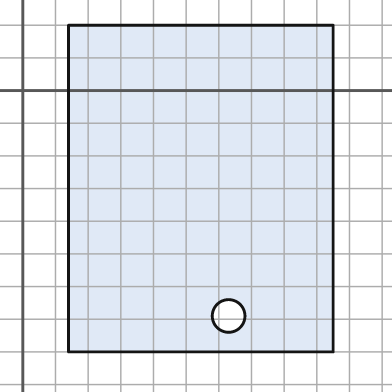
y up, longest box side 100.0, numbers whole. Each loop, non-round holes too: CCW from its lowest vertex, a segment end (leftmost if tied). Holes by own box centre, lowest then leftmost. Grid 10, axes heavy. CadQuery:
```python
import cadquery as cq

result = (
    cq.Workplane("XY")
    .moveTo(14.0, -80.0)
    .lineTo(95.0, -80.0)
    .lineTo(95.0, 20.0)
    .lineTo(14.0, 20.0)
    .close()
    .moveTo(63.0, -69.0)
    .circle(5.0)
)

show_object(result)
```